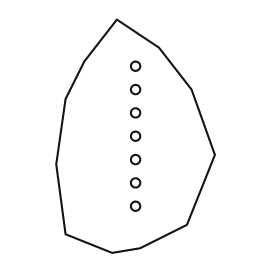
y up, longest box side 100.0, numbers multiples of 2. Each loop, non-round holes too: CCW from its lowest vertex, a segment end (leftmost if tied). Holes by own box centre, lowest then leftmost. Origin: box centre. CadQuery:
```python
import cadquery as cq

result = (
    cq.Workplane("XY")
    .moveTo(-10.0, -50.0)
    .lineTo(2.0, -48.0)
    .lineTo(22.0, -38.0)
    .lineTo(34.0, -8.0)
    .lineTo(24.0, 20.0)
    .lineTo(10.0, 38.0)
    .lineTo(-8.0, 50.0)
    .lineTo(-22.0, 32.0)
    .lineTo(-30.0, 16.0)
    .lineTo(-34.0, -12.0)
    .lineTo(-30.0, -42.0)
    .close()
    .moveTo(0.0, -30.0)
    .circle(2.0)
    .moveTo(0.0, -20.0)
    .circle(2.0)
    .moveTo(0.0, -10.0)
    .circle(2.0)
    .moveTo(0.0, 0.0)
    .circle(2.0)
    .moveTo(0.0, 10.0)
    .circle(2.0)
    .moveTo(0.0, 20.0)
    .circle(2.0)
    .moveTo(0.0, 30.0)
    .circle(2.0)
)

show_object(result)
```